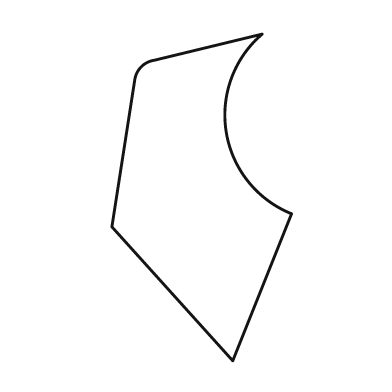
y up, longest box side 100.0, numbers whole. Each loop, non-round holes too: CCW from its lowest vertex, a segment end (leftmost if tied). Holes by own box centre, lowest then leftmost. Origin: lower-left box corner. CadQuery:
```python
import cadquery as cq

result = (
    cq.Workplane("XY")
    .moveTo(37.0, 0.0)
    .lineTo(55.0, 45.0)
    .threePointArc((35.0, 70.0), (46.0, 100.0))
    .lineTo(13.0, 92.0)
    .threePointArc((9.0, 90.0), (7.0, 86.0))
    .lineTo(0.0, 41.0)
    .close()
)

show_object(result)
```